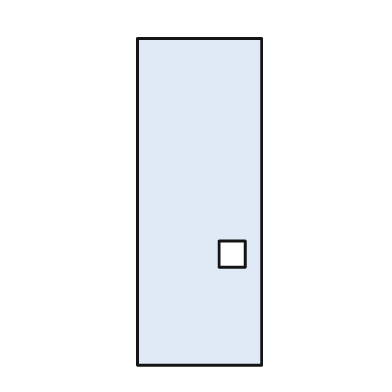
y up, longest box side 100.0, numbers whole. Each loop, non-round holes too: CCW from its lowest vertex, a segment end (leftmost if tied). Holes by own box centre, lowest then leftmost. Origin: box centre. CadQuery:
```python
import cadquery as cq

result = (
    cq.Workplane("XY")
    .moveTo(-19.0, -50.0)
    .lineTo(19.0, -50.0)
    .lineTo(19.0, 50.0)
    .lineTo(-19.0, 50.0)
    .close()
    .moveTo(6.0, -20.0)
    .lineTo(14.0, -20.0)
    .lineTo(14.0, -12.0)
    .lineTo(6.0, -12.0)
    .close()
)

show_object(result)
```